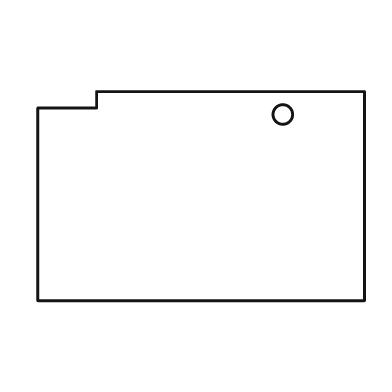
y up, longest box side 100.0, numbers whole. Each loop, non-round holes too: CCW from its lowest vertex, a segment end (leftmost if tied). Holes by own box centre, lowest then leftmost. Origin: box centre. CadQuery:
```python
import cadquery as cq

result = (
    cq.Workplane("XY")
    .moveTo(-50.0, -32.0)
    .lineTo(50.0, -32.0)
    .lineTo(50.0, 32.0)
    .lineTo(-32.0, 32.0)
    .lineTo(-32.0, 27.0)
    .lineTo(-50.0, 27.0)
    .close()
    .moveTo(25.0, 25.0)
    .circle(3.0)
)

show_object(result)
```